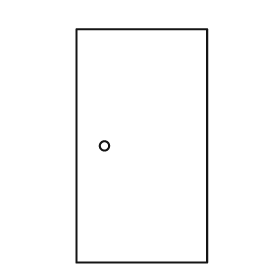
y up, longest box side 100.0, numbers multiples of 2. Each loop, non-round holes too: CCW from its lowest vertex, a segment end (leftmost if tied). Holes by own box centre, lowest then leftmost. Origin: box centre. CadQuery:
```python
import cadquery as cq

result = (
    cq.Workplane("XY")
    .moveTo(-28.0, -50.0)
    .lineTo(28.0, -50.0)
    .lineTo(28.0, 50.0)
    .lineTo(-28.0, 50.0)
    .close()
    .moveTo(-16.0, 0.0)
    .circle(2.0)
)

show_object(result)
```